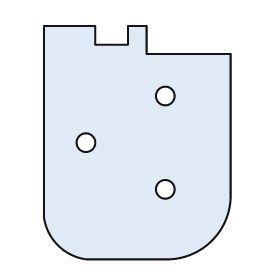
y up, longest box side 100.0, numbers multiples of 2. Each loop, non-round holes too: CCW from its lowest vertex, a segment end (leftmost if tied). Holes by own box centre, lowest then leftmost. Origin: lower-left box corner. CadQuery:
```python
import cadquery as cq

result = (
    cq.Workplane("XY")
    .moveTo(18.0, 0.0)
    .lineTo(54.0, 0.0)
    .threePointArc((72.0, 8.0), (80.0, 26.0))
    .lineTo(80.0, 88.0)
    .lineTo(44.0, 88.0)
    .lineTo(44.0, 100.0)
    .lineTo(36.0, 100.0)
    .lineTo(36.0, 92.0)
    .lineTo(22.0, 92.0)
    .lineTo(22.0, 100.0)
    .lineTo(0.0, 100.0)
    .lineTo(0.0, 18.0)
    .threePointArc((6.0, 6.0), (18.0, 0.0))
    .close()
    .moveTo(52.0, 30.0)
    .circle(4.0)
    .moveTo(18.0, 50.0)
    .circle(4.0)
    .moveTo(52.0, 70.0)
    .circle(4.0)
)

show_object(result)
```